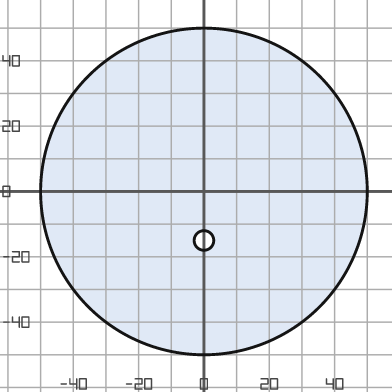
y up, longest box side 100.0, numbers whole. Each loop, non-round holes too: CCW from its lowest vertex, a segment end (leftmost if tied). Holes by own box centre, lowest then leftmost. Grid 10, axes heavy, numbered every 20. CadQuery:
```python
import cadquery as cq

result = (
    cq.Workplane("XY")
    .moveTo(0.0, 0.0)
    .circle(50.0)
    .moveTo(0.0, -15.0)
    .circle(3.0)
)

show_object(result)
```